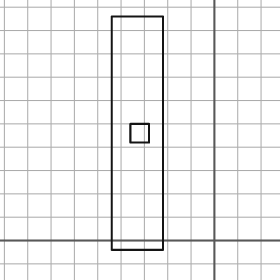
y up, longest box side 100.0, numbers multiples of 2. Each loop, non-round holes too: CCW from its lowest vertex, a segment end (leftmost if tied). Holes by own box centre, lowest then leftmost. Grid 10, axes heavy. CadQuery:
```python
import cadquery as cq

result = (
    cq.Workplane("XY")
    .moveTo(-44.0, -4.0)
    .lineTo(-22.0, -4.0)
    .lineTo(-22.0, 96.0)
    .lineTo(-44.0, 96.0)
    .close()
    .moveTo(-36.0, 42.0)
    .lineTo(-28.0, 42.0)
    .lineTo(-28.0, 50.0)
    .lineTo(-36.0, 50.0)
    .close()
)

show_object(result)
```